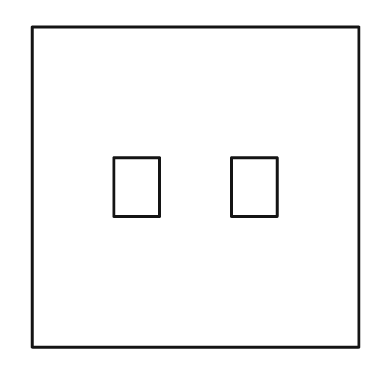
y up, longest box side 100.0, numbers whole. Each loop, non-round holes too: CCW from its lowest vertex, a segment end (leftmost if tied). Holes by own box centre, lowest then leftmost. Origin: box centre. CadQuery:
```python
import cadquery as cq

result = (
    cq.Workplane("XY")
    .moveTo(-50.0, -49.0)
    .lineTo(50.0, -49.0)
    .lineTo(50.0, 49.0)
    .lineTo(-50.0, 49.0)
    .close()
    .moveTo(-25.0, -9.0)
    .lineTo(-11.0, -9.0)
    .lineTo(-11.0, 9.0)
    .lineTo(-25.0, 9.0)
    .close()
    .moveTo(11.0, -9.0)
    .lineTo(25.0, -9.0)
    .lineTo(25.0, 9.0)
    .lineTo(11.0, 9.0)
    .close()
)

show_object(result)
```